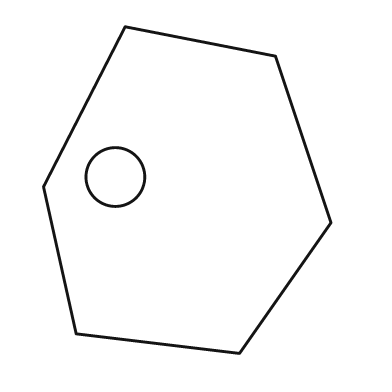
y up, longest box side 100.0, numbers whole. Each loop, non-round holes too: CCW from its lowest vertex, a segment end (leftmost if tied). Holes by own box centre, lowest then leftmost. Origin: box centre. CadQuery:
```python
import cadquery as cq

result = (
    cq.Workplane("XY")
    .moveTo(16.0, -50.0)
    .lineTo(44.0, -10.0)
    .lineTo(27.0, 41.0)
    .lineTo(-19.0, 50.0)
    .lineTo(-44.0, 1.0)
    .lineTo(-34.0, -44.0)
    .close()
    .moveTo(-22.0, 4.0)
    .circle(9.0)
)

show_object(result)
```